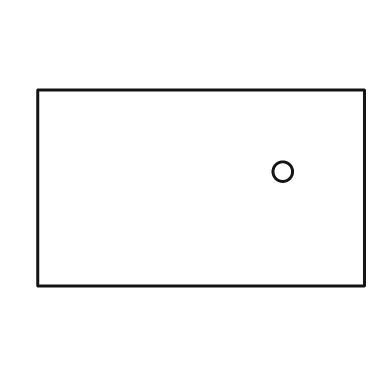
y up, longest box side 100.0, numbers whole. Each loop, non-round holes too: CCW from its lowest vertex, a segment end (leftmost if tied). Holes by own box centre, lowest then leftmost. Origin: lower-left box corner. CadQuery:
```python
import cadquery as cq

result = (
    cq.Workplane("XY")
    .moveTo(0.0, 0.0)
    .lineTo(100.0, 0.0)
    .lineTo(100.0, 60.0)
    .lineTo(0.0, 60.0)
    .close()
    .moveTo(75.0, 35.0)
    .circle(3.0)
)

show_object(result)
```